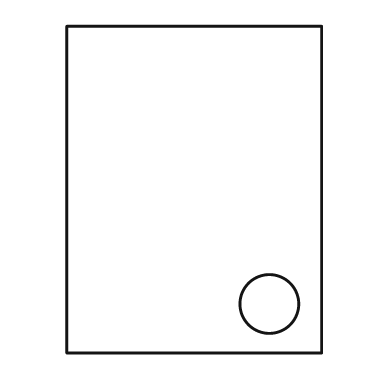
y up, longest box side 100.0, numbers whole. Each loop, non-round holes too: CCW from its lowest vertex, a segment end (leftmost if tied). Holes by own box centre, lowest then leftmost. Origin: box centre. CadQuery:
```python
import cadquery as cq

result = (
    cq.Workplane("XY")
    .moveTo(-39.0, -50.0)
    .lineTo(39.0, -50.0)
    .lineTo(39.0, 50.0)
    .lineTo(-39.0, 50.0)
    .close()
    .moveTo(23.0, -35.0)
    .circle(9.0)
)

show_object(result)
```